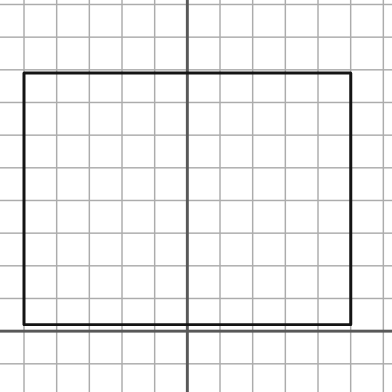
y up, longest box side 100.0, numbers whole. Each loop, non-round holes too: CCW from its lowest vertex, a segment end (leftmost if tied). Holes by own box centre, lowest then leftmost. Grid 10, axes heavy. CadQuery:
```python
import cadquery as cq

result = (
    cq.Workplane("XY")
    .moveTo(-50.0, 2.0)
    .lineTo(50.0, 2.0)
    .lineTo(50.0, 79.0)
    .lineTo(-50.0, 79.0)
    .close()
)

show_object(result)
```